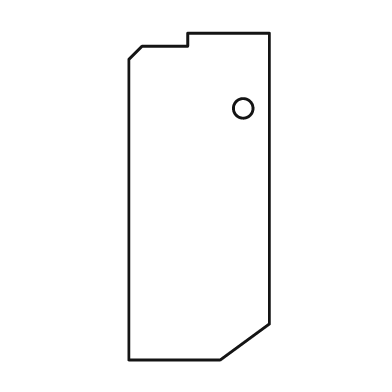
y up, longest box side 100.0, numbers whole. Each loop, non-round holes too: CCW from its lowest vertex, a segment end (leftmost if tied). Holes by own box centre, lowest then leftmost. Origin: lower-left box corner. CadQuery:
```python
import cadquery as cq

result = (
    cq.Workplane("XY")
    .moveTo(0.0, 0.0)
    .lineTo(28.0, 0.0)
    .lineTo(43.0, 11.0)
    .lineTo(43.0, 100.0)
    .lineTo(18.0, 100.0)
    .lineTo(18.0, 96.0)
    .lineTo(4.0, 96.0)
    .lineTo(0.0, 92.0)
    .close()
    .moveTo(35.0, 77.0)
    .circle(3.0)
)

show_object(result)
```